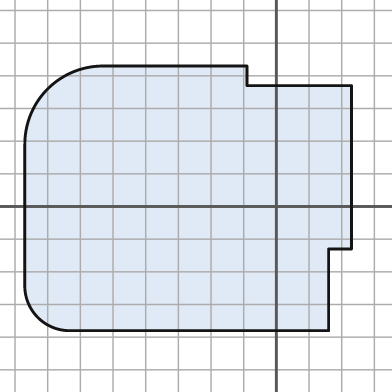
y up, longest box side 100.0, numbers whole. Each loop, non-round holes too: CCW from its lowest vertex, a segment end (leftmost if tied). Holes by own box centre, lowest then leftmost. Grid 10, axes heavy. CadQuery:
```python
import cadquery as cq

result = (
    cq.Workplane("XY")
    .moveTo(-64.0, -38.0)
    .lineTo(16.0, -38.0)
    .lineTo(16.0, -13.0)
    .lineTo(23.0, -13.0)
    .lineTo(23.0, 37.0)
    .lineTo(-9.0, 37.0)
    .lineTo(-9.0, 43.0)
    .lineTo(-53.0, 43.0)
    .threePointArc((-70.0, 36.0), (-77.0, 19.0))
    .lineTo(-77.0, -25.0)
    .threePointArc((-73.0, -34.0), (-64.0, -38.0))
    .close()
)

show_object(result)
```